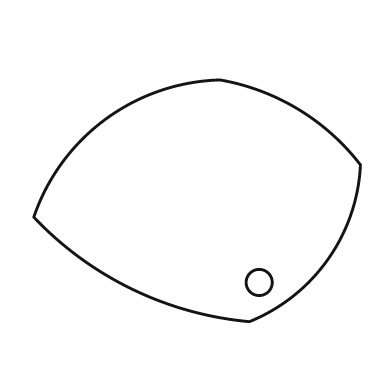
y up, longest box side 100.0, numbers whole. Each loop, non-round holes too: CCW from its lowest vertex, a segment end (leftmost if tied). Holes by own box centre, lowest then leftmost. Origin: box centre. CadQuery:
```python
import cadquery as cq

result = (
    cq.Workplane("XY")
    .moveTo(16.0, -37.0)
    .threePointArc((40.0, -18.0), (50.0, 11.0))
    .threePointArc((31.0, 28.0), (7.0, 37.0))
    .threePointArc((-28.0, 25.0), (-50.0, -5.0))
    .threePointArc((-20.0, -27.0), (16.0, -37.0))
    .close()
    .moveTo(19.0, -25.0)
    .circle(4.0)
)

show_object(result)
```